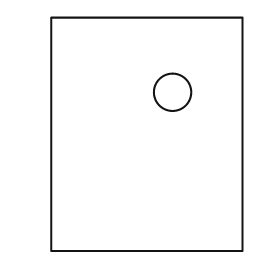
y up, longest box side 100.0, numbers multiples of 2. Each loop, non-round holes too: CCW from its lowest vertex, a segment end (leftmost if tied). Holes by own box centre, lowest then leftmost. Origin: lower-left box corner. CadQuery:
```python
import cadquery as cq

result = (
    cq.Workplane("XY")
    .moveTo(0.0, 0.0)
    .lineTo(82.0, 0.0)
    .lineTo(82.0, 100.0)
    .lineTo(0.0, 100.0)
    .close()
    .moveTo(52.0, 68.0)
    .circle(8.0)
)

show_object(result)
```